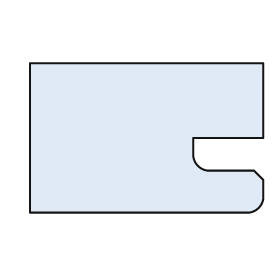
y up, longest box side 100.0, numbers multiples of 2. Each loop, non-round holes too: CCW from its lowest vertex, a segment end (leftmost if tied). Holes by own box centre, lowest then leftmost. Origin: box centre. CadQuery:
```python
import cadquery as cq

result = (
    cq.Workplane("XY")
    .moveTo(-50.0, -32.0)
    .lineTo(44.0, -32.0)
    .threePointArc((48.0, -30.0), (50.0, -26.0))
    .lineTo(50.0, -18.0)
    .lineTo(46.0, -14.0)
    .lineTo(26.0, -14.0)
    .threePointArc((22.0, -12.0), (20.0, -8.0))
    .lineTo(20.0, 0.0)
    .lineTo(50.0, 0.0)
    .lineTo(50.0, 32.0)
    .lineTo(-50.0, 32.0)
    .close()
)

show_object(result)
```